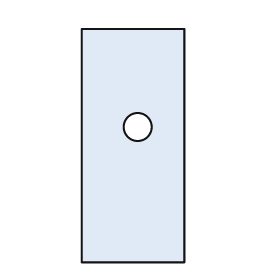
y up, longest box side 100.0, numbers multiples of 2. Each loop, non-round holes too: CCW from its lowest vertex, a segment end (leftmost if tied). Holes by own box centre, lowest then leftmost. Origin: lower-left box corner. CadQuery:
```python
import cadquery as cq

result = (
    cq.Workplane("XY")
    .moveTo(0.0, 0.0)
    .lineTo(44.0, 0.0)
    .lineTo(44.0, 100.0)
    .lineTo(0.0, 100.0)
    .close()
    .moveTo(24.0, 58.0)
    .circle(6.0)
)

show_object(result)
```